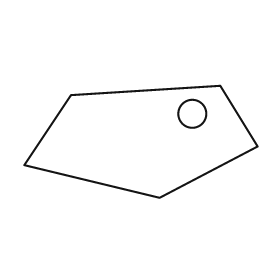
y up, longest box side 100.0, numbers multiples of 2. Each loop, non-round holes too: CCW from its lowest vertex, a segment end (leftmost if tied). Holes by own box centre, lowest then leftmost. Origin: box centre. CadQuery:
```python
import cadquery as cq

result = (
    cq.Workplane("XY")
    .moveTo(8.0, -24.0)
    .lineTo(50.0, -2.0)
    .lineTo(34.0, 24.0)
    .lineTo(-30.0, 20.0)
    .lineTo(-50.0, -10.0)
    .close()
    .moveTo(22.0, 12.0)
    .circle(6.0)
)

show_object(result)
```